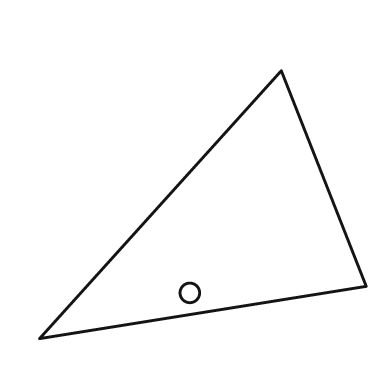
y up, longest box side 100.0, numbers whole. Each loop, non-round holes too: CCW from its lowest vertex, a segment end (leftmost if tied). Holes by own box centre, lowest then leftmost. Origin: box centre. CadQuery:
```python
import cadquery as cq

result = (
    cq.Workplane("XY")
    .moveTo(-50.0, -41.0)
    .lineTo(50.0, -25.0)
    .lineTo(24.0, 41.0)
    .close()
    .moveTo(-4.0, -27.0)
    .circle(3.0)
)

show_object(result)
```